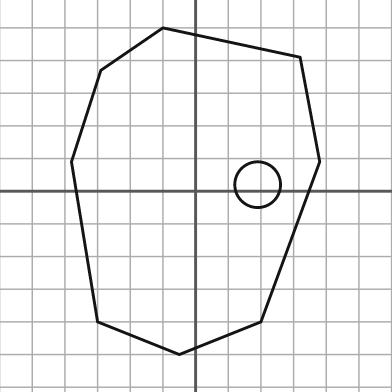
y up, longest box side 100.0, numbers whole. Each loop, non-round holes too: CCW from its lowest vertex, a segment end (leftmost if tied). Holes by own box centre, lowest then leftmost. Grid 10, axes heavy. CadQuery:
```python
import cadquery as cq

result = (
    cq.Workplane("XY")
    .moveTo(-5.0, -50.0)
    .lineTo(20.0, -40.0)
    .lineTo(38.0, 9.0)
    .lineTo(32.0, 41.0)
    .lineTo(-10.0, 50.0)
    .lineTo(-29.0, 37.0)
    .lineTo(-38.0, 9.0)
    .lineTo(-30.0, -40.0)
    .close()
    .moveTo(19.0, 2.0)
    .circle(7.0)
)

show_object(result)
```